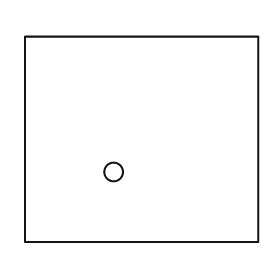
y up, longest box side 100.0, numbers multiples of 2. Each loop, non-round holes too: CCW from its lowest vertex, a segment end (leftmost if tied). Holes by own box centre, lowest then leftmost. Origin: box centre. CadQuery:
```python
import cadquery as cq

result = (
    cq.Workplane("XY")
    .moveTo(-50.0, -44.0)
    .lineTo(50.0, -44.0)
    .lineTo(50.0, 44.0)
    .lineTo(-50.0, 44.0)
    .close()
    .moveTo(-12.0, -14.0)
    .circle(4.0)
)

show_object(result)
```